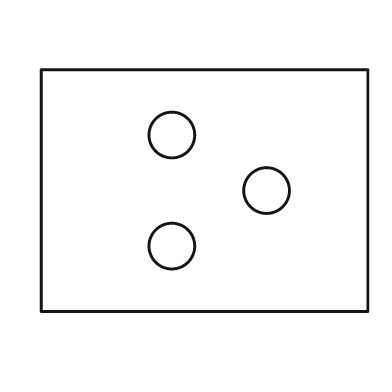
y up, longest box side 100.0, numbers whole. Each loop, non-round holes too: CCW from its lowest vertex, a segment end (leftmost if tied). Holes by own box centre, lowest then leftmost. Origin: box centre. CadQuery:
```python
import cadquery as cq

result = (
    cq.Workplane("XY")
    .moveTo(-50.0, -37.0)
    .lineTo(50.0, -37.0)
    .lineTo(50.0, 37.0)
    .lineTo(-50.0, 37.0)
    .close()
    .moveTo(-10.0, -17.0)
    .circle(7.0)
    .moveTo(19.0, 0.0)
    .circle(7.0)
    .moveTo(-10.0, 17.0)
    .circle(7.0)
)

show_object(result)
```